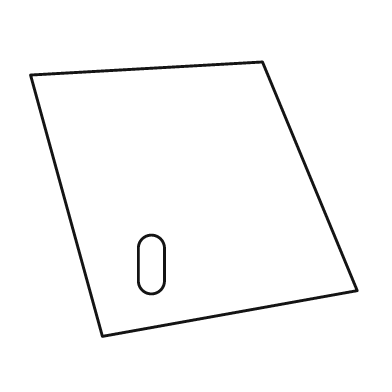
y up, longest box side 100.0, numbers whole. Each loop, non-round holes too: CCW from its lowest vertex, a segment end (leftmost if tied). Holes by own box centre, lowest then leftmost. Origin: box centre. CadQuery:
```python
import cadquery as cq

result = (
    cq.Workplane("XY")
    .moveTo(-28.0, -42.0)
    .lineTo(50.0, -28.0)
    .lineTo(21.0, 42.0)
    .lineTo(-50.0, 38.0)
    .close()
    .moveTo(-17.0, -25.0)
    .threePointArc((-13.0, -29.0), (-9.0, -25.0))
    .lineTo(-9.0, -15.0)
    .threePointArc((-13.0, -11.0), (-17.0, -15.0))
    .close()
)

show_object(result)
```